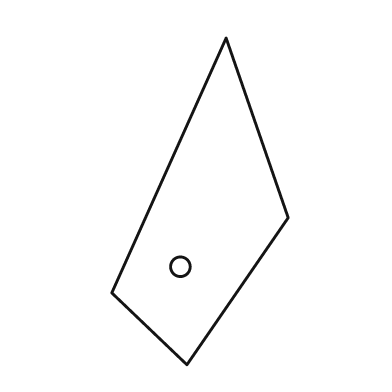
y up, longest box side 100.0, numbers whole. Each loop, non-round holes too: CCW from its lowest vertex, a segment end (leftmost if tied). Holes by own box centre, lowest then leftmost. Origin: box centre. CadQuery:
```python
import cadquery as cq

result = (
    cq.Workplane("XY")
    .moveTo(-4.0, -50.0)
    .lineTo(27.0, -5.0)
    .lineTo(8.0, 50.0)
    .lineTo(-27.0, -28.0)
    .close()
    .moveTo(-6.0, -20.0)
    .circle(3.0)
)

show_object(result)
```